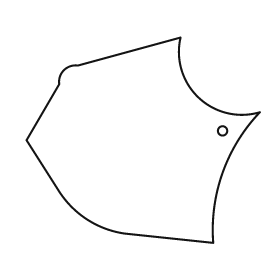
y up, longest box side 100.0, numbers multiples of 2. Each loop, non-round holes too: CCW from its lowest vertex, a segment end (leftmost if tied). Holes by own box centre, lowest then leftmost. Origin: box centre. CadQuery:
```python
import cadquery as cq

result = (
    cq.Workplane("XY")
    .moveTo(30.0, -44.0)
    .threePointArc((34.0, -14.0), (50.0, 12.0))
    .threePointArc((24.0, 18.0), (16.0, 44.0))
    .lineTo(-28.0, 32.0)
    .threePointArc((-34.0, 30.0), (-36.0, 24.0))
    .lineTo(-50.0, 0.0)
    .lineTo(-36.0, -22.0)
    .threePointArc((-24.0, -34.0), (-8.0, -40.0))
    .close()
    .moveTo(34.0, 4.0)
    .circle(2.0)
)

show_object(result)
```